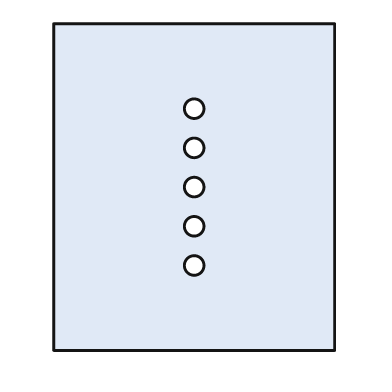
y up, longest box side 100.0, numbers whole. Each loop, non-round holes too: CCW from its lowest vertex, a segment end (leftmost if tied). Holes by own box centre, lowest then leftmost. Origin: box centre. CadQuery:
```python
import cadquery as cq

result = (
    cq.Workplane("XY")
    .moveTo(-43.0, -50.0)
    .lineTo(43.0, -50.0)
    .lineTo(43.0, 50.0)
    .lineTo(-43.0, 50.0)
    .close()
    .moveTo(0.0, -24.0)
    .circle(3.0)
    .moveTo(0.0, -12.0)
    .circle(3.0)
    .moveTo(0.0, 0.0)
    .circle(3.0)
    .moveTo(0.0, 12.0)
    .circle(3.0)
    .moveTo(0.0, 24.0)
    .circle(3.0)
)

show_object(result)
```